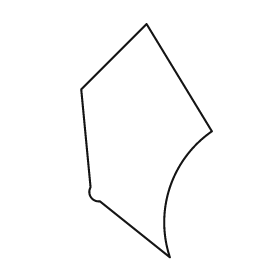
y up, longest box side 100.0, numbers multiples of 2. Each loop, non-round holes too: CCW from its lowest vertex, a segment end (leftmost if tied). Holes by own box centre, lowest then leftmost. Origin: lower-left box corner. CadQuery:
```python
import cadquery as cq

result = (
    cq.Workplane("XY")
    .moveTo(38.0, 0.0)
    .threePointArc((38.0, 30.0), (56.0, 54.0))
    .lineTo(28.0, 100.0)
    .lineTo(0.0, 72.0)
    .lineTo(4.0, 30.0)
    .threePointArc((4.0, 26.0), (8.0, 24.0))
    .close()
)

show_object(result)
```